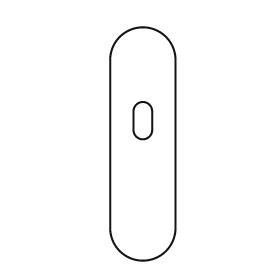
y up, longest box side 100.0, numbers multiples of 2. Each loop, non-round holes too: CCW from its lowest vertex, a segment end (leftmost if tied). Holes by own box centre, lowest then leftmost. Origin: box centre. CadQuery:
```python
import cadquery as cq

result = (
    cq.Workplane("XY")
    .moveTo(-14.0, -36.0)
    .threePointArc((0.0, -50.0), (14.0, -36.0))
    .lineTo(14.0, 36.0)
    .threePointArc((0.0, 50.0), (-14.0, 36.0))
    .close()
    .moveTo(-4.0, 6.0)
    .threePointArc((0.0, 2.0), (4.0, 6.0))
    .lineTo(4.0, 14.0)
    .threePointArc((0.0, 18.0), (-4.0, 14.0))
    .close()
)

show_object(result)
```